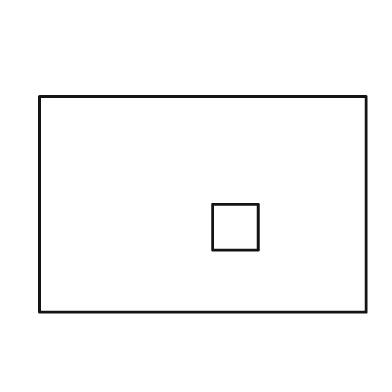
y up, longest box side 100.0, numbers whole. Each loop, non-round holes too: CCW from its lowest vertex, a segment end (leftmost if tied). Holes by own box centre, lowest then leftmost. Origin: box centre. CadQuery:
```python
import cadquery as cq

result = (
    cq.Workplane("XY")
    .moveTo(-50.0, -33.0)
    .lineTo(50.0, -33.0)
    .lineTo(50.0, 33.0)
    .lineTo(-50.0, 33.0)
    .close()
    .moveTo(3.0, -14.0)
    .lineTo(17.0, -14.0)
    .lineTo(17.0, 0.0)
    .lineTo(3.0, 0.0)
    .close()
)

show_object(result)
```